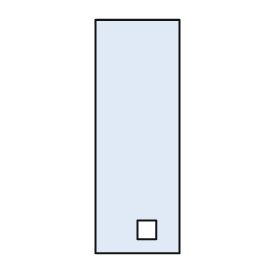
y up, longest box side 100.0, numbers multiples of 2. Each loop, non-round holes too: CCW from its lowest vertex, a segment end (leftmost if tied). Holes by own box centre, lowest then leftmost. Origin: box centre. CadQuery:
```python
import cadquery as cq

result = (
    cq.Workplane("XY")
    .moveTo(-18.0, -50.0)
    .lineTo(18.0, -50.0)
    .lineTo(18.0, 50.0)
    .lineTo(-18.0, 50.0)
    .close()
    .moveTo(0.0, -44.0)
    .lineTo(8.0, -44.0)
    .lineTo(8.0, -36.0)
    .lineTo(0.0, -36.0)
    .close()
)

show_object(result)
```